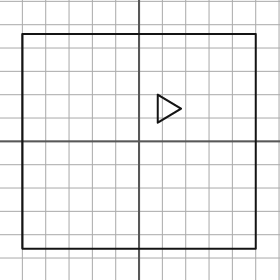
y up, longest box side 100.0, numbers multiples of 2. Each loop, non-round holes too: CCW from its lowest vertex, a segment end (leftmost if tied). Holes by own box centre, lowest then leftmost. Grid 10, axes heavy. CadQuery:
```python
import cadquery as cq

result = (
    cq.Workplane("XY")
    .moveTo(-50.0, -46.0)
    .lineTo(50.0, -46.0)
    .lineTo(50.0, 46.0)
    .lineTo(-50.0, 46.0)
    .close()
    .moveTo(8.0, 8.0)
    .lineTo(18.0, 14.0)
    .lineTo(8.0, 20.0)
    .close()
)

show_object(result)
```